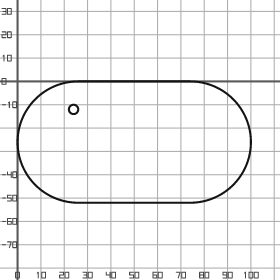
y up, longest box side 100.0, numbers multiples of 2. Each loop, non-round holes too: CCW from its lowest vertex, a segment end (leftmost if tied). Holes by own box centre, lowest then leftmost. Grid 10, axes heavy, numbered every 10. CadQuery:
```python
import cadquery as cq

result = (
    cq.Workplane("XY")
    .moveTo(26.0, -52.0)
    .lineTo(74.0, -52.0)
    .threePointArc((100.0, -26.0), (74.0, 0.0))
    .lineTo(26.0, 0.0)
    .threePointArc((0.0, -26.0), (26.0, -52.0))
    .close()
    .moveTo(24.0, -12.0)
    .circle(2.0)
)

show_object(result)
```